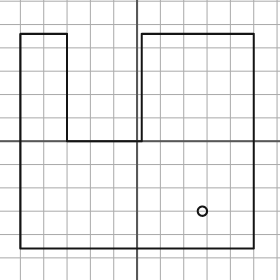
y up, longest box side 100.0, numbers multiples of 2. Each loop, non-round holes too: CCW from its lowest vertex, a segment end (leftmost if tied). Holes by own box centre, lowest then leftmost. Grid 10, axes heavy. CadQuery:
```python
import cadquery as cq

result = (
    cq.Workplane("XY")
    .moveTo(-50.0, -46.0)
    .lineTo(50.0, -46.0)
    .lineTo(50.0, 46.0)
    .lineTo(2.0, 46.0)
    .lineTo(2.0, 0.0)
    .lineTo(-30.0, 0.0)
    .lineTo(-30.0, 46.0)
    .lineTo(-50.0, 46.0)
    .close()
    .moveTo(28.0, -30.0)
    .circle(2.0)
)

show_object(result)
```